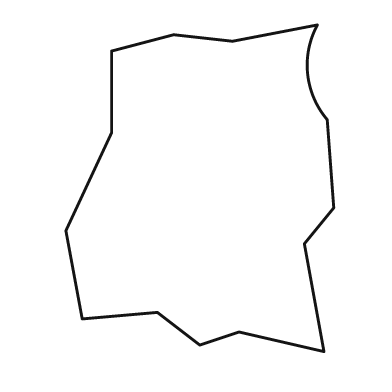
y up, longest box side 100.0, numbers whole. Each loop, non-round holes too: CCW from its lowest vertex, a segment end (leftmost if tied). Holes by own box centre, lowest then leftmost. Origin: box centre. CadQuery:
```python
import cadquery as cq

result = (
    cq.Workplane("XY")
    .moveTo(38.0, -50.0)
    .lineTo(32.0, -17.0)
    .lineTo(41.0, -6.0)
    .lineTo(39.0, 21.0)
    .threePointArc((33.0, 35.0), (36.0, 50.0))
    .lineTo(10.0, 45.0)
    .lineTo(-8.0, 47.0)
    .lineTo(-27.0, 42.0)
    .lineTo(-27.0, 17.0)
    .lineTo(-41.0, -13.0)
    .lineTo(-36.0, -40.0)
    .lineTo(-13.0, -38.0)
    .lineTo(0.0, -48.0)
    .lineTo(12.0, -44.0)
    .close()
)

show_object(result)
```